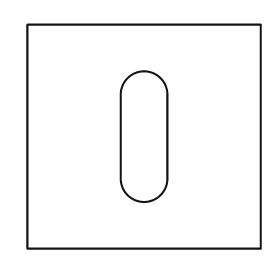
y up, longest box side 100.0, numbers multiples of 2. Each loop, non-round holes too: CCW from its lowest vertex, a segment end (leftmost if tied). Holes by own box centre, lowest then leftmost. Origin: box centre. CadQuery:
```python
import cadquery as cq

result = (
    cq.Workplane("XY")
    .moveTo(-50.0, -48.0)
    .lineTo(50.0, -48.0)
    .lineTo(50.0, 48.0)
    .lineTo(-50.0, 48.0)
    .close()
    .moveTo(-10.0, -18.0)
    .threePointArc((0.0, -28.0), (10.0, -18.0))
    .lineTo(10.0, 18.0)
    .threePointArc((0.0, 28.0), (-10.0, 18.0))
    .close()
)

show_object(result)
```